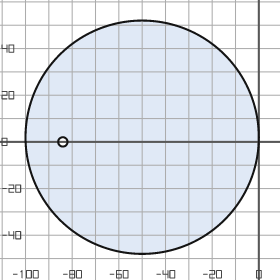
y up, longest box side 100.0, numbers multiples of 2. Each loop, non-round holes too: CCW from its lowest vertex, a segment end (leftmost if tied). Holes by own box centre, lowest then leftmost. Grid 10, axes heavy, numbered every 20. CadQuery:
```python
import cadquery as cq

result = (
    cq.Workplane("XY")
    .moveTo(-50.0, 2.0)
    .circle(50.0)
    .moveTo(-84.0, 0.0)
    .circle(2.0)
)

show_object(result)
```